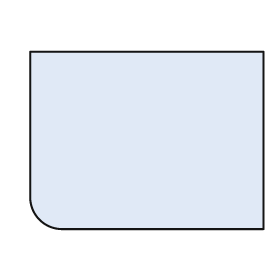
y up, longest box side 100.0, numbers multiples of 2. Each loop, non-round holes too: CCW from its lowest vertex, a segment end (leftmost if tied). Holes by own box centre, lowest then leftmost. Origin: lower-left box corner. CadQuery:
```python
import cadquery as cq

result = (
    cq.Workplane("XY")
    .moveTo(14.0, 0.0)
    .lineTo(100.0, 0.0)
    .lineTo(100.0, 76.0)
    .lineTo(0.0, 76.0)
    .lineTo(0.0, 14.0)
    .threePointArc((4.0, 4.0), (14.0, 0.0))
    .close()
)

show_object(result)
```